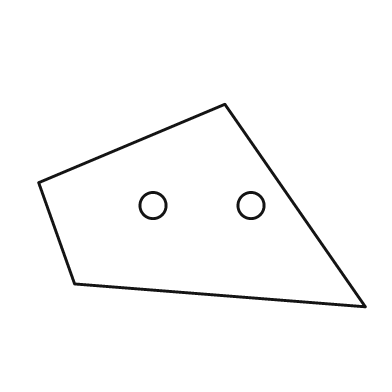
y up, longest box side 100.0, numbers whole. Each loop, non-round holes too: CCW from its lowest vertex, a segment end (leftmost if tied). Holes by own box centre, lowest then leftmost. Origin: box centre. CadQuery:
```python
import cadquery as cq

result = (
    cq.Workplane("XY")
    .moveTo(50.0, -31.0)
    .lineTo(7.0, 31.0)
    .lineTo(-50.0, 7.0)
    .lineTo(-39.0, -24.0)
    .close()
    .moveTo(-15.0, 0.0)
    .circle(4.0)
    .moveTo(15.0, 0.0)
    .circle(4.0)
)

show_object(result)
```